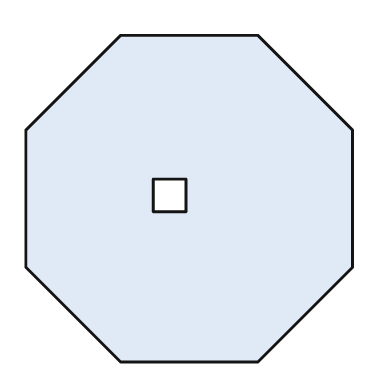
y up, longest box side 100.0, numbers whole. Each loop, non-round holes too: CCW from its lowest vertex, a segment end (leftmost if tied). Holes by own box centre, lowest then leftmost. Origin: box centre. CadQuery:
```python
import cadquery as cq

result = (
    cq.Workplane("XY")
    .moveTo(-21.0, -50.0)
    .lineTo(21.0, -50.0)
    .lineTo(50.0, -21.0)
    .lineTo(50.0, 21.0)
    .lineTo(21.0, 50.0)
    .lineTo(-21.0, 50.0)
    .lineTo(-50.0, 21.0)
    .lineTo(-50.0, -21.0)
    .close()
    .moveTo(-11.0, -4.0)
    .lineTo(-1.0, -4.0)
    .lineTo(-1.0, 6.0)
    .lineTo(-11.0, 6.0)
    .close()
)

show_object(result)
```